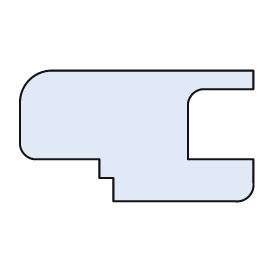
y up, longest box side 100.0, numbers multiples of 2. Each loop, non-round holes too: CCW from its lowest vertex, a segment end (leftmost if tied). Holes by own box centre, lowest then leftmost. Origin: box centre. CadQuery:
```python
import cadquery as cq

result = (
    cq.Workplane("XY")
    .moveTo(-10.0, -28.0)
    .lineTo(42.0, -28.0)
    .threePointArc((48.0, -26.0), (50.0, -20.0))
    .lineTo(50.0, -10.0)
    .lineTo(22.0, -10.0)
    .lineTo(22.0, 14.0)
    .threePointArc((24.0, 18.0), (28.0, 20.0))
    .lineTo(50.0, 20.0)
    .lineTo(50.0, 28.0)
    .lineTo(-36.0, 28.0)
    .threePointArc((-46.0, 24.0), (-50.0, 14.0))
    .lineTo(-50.0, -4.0)
    .threePointArc((-48.0, -8.0), (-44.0, -10.0))
    .lineTo(-16.0, -10.0)
    .lineTo(-16.0, -18.0)
    .lineTo(-10.0, -18.0)
    .close()
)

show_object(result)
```